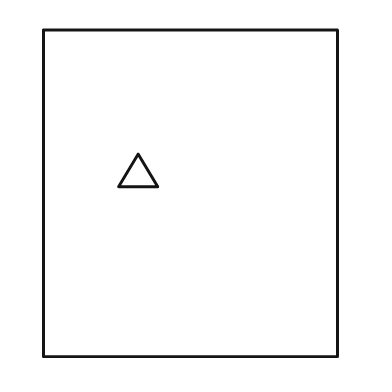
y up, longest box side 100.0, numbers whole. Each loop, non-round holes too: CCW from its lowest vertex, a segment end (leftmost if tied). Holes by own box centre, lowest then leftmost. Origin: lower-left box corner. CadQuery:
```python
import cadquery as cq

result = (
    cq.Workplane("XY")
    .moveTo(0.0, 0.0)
    .lineTo(90.0, 0.0)
    .lineTo(90.0, 100.0)
    .lineTo(0.0, 100.0)
    .close()
    .moveTo(23.0, 52.0)
    .lineTo(35.0, 52.0)
    .lineTo(29.0, 62.0)
    .close()
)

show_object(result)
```